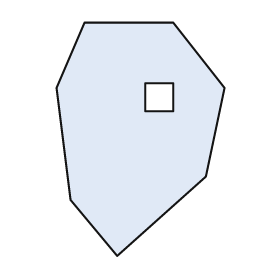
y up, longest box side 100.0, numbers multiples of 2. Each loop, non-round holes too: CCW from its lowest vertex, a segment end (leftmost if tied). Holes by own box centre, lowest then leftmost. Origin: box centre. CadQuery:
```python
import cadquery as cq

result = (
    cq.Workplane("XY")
    .moveTo(-10.0, -50.0)
    .lineTo(28.0, -16.0)
    .lineTo(36.0, 22.0)
    .lineTo(14.0, 50.0)
    .lineTo(-24.0, 50.0)
    .lineTo(-36.0, 22.0)
    .lineTo(-30.0, -26.0)
    .close()
    .moveTo(2.0, 12.0)
    .lineTo(14.0, 12.0)
    .lineTo(14.0, 24.0)
    .lineTo(2.0, 24.0)
    .close()
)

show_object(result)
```